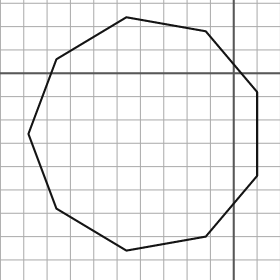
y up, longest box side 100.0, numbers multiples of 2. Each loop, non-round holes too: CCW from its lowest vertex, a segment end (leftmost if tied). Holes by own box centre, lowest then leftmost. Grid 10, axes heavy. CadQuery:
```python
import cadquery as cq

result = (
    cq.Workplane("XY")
    .moveTo(-46.0, -76.0)
    .lineTo(-12.0, -70.0)
    .lineTo(10.0, -44.0)
    .lineTo(10.0, -8.0)
    .lineTo(-12.0, 18.0)
    .lineTo(-46.0, 24.0)
    .lineTo(-76.0, 6.0)
    .lineTo(-88.0, -26.0)
    .lineTo(-76.0, -58.0)
    .close()
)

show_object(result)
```